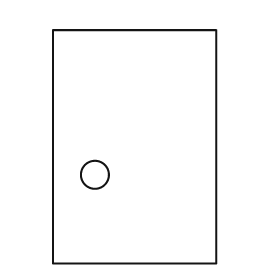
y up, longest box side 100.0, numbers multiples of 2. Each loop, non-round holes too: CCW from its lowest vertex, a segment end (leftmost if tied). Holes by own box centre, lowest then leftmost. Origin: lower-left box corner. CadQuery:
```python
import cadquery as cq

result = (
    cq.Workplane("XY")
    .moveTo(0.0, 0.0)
    .lineTo(70.0, 0.0)
    .lineTo(70.0, 100.0)
    .lineTo(0.0, 100.0)
    .close()
    .moveTo(18.0, 38.0)
    .circle(6.0)
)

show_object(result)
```